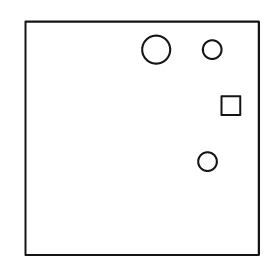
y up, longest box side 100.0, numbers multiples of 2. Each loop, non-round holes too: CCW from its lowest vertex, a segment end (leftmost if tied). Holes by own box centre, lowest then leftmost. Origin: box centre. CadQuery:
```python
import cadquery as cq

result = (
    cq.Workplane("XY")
    .moveTo(-50.0, -50.0)
    .lineTo(50.0, -50.0)
    .lineTo(50.0, 50.0)
    .lineTo(-50.0, 50.0)
    .close()
    .moveTo(28.0, -10.0)
    .circle(4.0)
    .moveTo(34.0, 10.0)
    .lineTo(42.0, 10.0)
    .lineTo(42.0, 18.0)
    .lineTo(34.0, 18.0)
    .close()
    .moveTo(6.0, 38.0)
    .circle(6.0)
    .moveTo(30.0, 38.0)
    .circle(4.0)
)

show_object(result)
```